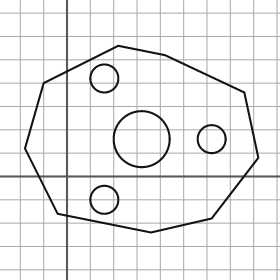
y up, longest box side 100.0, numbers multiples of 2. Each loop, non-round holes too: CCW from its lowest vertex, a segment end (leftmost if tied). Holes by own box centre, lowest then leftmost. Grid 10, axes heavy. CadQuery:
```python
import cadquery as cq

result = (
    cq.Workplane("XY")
    .moveTo(36.0, -24.0)
    .lineTo(62.0, -18.0)
    .lineTo(82.0, 8.0)
    .lineTo(76.0, 36.0)
    .lineTo(42.0, 52.0)
    .lineTo(22.0, 56.0)
    .lineTo(-10.0, 40.0)
    .lineTo(-18.0, 12.0)
    .lineTo(-4.0, -16.0)
    .close()
    .moveTo(16.0, -10.0)
    .circle(6.0)
    .moveTo(32.0, 16.0)
    .circle(12.0)
    .moveTo(62.0, 16.0)
    .circle(6.0)
    .moveTo(16.0, 42.0)
    .circle(6.0)
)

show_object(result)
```